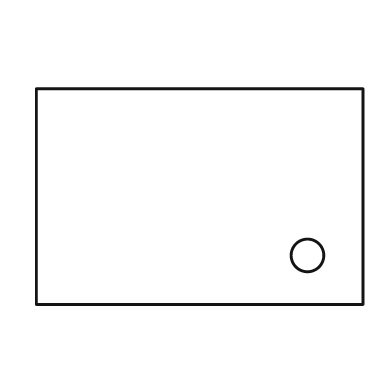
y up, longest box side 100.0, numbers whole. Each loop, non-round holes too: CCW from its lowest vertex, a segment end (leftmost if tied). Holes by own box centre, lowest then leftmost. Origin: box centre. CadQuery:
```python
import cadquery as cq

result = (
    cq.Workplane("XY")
    .moveTo(-50.0, -33.0)
    .lineTo(50.0, -33.0)
    .lineTo(50.0, 33.0)
    .lineTo(-50.0, 33.0)
    .close()
    .moveTo(33.0, -18.0)
    .circle(5.0)
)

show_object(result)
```